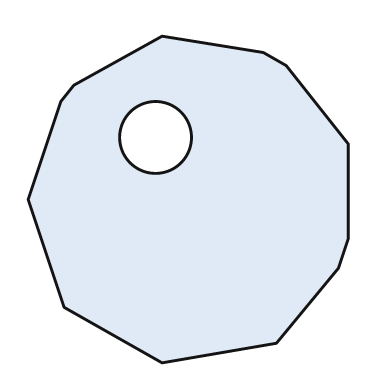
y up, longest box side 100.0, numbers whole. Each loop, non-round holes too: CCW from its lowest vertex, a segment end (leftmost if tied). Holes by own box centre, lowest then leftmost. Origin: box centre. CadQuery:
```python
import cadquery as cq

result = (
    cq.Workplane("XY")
    .moveTo(-8.0, -50.0)
    .lineTo(27.0, -44.0)
    .lineTo(46.0, -21.0)
    .lineTo(49.0, -12.0)
    .lineTo(49.0, 17.0)
    .lineTo(30.0, 41.0)
    .lineTo(23.0, 45.0)
    .lineTo(-8.0, 50.0)
    .lineTo(-35.0, 35.0)
    .lineTo(-39.0, 30.0)
    .lineTo(-49.0, 0.0)
    .lineTo(-38.0, -33.0)
    .close()
    .moveTo(-10.0, 19.0)
    .circle(11.0)
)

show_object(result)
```